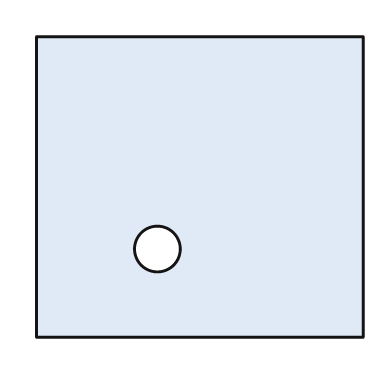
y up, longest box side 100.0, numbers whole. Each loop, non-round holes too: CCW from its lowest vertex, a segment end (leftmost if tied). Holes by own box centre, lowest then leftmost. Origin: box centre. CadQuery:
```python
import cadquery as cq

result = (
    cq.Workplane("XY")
    .moveTo(-50.0, -46.0)
    .lineTo(50.0, -46.0)
    .lineTo(50.0, 46.0)
    .lineTo(-50.0, 46.0)
    .close()
    .moveTo(-13.0, -19.0)
    .circle(7.0)
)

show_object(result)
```